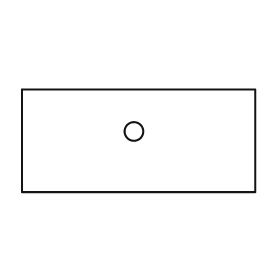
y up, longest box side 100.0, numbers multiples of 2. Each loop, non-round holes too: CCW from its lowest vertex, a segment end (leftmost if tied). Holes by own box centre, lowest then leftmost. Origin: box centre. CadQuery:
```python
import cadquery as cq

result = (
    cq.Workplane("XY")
    .moveTo(-50.0, -22.0)
    .lineTo(50.0, -22.0)
    .lineTo(50.0, 22.0)
    .lineTo(-50.0, 22.0)
    .close()
    .moveTo(-2.0, 4.0)
    .circle(4.0)
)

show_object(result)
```